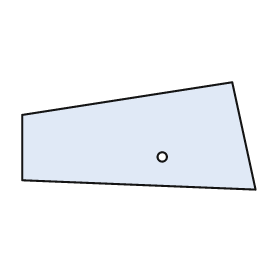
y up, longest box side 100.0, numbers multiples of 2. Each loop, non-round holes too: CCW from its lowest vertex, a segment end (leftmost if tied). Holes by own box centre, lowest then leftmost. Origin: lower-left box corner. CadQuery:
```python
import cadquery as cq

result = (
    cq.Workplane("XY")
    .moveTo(100.0, 0.0)
    .lineTo(90.0, 46.0)
    .lineTo(0.0, 32.0)
    .lineTo(0.0, 4.0)
    .close()
    .moveTo(60.0, 14.0)
    .circle(2.0)
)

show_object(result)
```